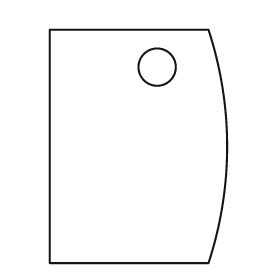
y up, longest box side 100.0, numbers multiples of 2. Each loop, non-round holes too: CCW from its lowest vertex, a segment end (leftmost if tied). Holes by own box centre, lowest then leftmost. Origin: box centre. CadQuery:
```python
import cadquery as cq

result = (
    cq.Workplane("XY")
    .moveTo(-38.0, -50.0)
    .lineTo(30.0, -50.0)
    .threePointArc((38.0, 0.0), (30.0, 50.0))
    .lineTo(-38.0, 50.0)
    .close()
    .moveTo(8.0, 34.0)
    .circle(8.0)
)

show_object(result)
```